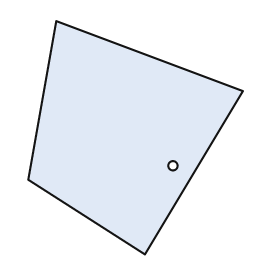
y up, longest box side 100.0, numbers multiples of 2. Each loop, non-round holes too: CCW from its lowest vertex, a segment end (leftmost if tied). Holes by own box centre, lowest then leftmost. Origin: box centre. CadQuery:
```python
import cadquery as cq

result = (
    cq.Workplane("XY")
    .moveTo(4.0, -50.0)
    .lineTo(46.0, 20.0)
    .lineTo(-34.0, 50.0)
    .lineTo(-46.0, -18.0)
    .close()
    .moveTo(16.0, -12.0)
    .circle(2.0)
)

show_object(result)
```